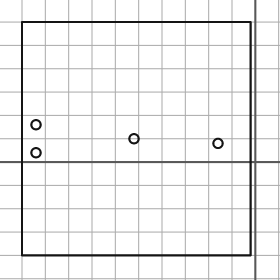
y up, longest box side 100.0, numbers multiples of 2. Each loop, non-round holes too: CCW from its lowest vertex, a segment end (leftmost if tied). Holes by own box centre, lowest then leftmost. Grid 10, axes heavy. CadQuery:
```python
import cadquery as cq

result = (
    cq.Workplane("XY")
    .moveTo(-100.0, -40.0)
    .lineTo(-2.0, -40.0)
    .lineTo(-2.0, 60.0)
    .lineTo(-100.0, 60.0)
    .close()
    .moveTo(-94.0, 4.0)
    .circle(2.0)
    .moveTo(-16.0, 8.0)
    .circle(2.0)
    .moveTo(-52.0, 10.0)
    .circle(2.0)
    .moveTo(-94.0, 16.0)
    .circle(2.0)
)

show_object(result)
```